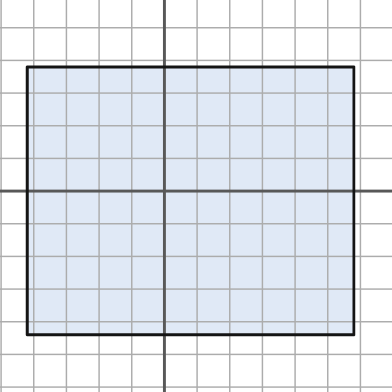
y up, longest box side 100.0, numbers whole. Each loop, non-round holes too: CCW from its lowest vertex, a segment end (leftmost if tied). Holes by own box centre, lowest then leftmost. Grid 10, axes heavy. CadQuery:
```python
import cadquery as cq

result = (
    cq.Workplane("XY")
    .moveTo(-42.0, -44.0)
    .lineTo(58.0, -44.0)
    .lineTo(58.0, 38.0)
    .lineTo(-42.0, 38.0)
    .close()
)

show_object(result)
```